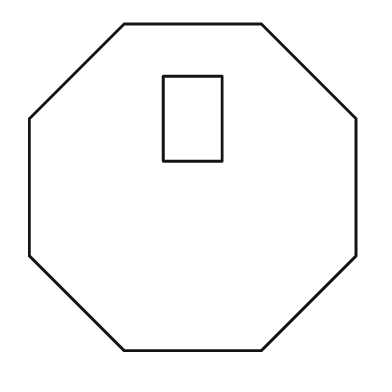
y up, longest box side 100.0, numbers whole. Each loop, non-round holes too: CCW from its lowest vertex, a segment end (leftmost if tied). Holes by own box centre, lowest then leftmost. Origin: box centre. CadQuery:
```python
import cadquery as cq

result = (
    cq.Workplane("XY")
    .moveTo(-21.0, -50.0)
    .lineTo(21.0, -50.0)
    .lineTo(50.0, -21.0)
    .lineTo(50.0, 21.0)
    .lineTo(21.0, 50.0)
    .lineTo(-21.0, 50.0)
    .lineTo(-50.0, 21.0)
    .lineTo(-50.0, -21.0)
    .close()
    .moveTo(-9.0, 8.0)
    .lineTo(9.0, 8.0)
    .lineTo(9.0, 34.0)
    .lineTo(-9.0, 34.0)
    .close()
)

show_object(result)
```